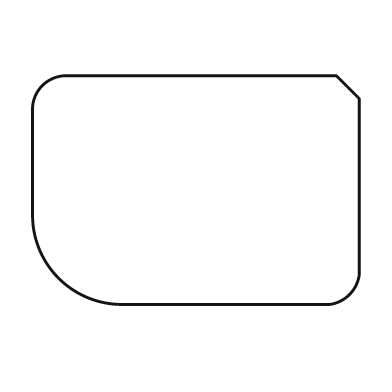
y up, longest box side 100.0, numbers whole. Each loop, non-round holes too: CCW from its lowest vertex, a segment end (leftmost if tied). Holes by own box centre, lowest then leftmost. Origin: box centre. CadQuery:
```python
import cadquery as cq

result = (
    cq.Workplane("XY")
    .moveTo(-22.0, -35.0)
    .lineTo(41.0, -35.0)
    .threePointArc((47.0, -32.0), (50.0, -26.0))
    .lineTo(50.0, 28.0)
    .lineTo(43.0, 35.0)
    .lineTo(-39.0, 35.0)
    .threePointArc((-47.0, 32.0), (-50.0, 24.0))
    .lineTo(-50.0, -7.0)
    .threePointArc((-42.0, -27.0), (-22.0, -35.0))
    .close()
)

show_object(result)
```